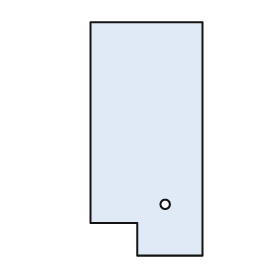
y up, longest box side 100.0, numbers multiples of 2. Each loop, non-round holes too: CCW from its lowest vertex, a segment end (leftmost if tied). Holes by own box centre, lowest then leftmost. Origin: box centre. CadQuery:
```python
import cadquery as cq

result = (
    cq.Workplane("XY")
    .moveTo(-4.0, -50.0)
    .lineTo(24.0, -50.0)
    .lineTo(24.0, 50.0)
    .lineTo(-24.0, 50.0)
    .lineTo(-24.0, -36.0)
    .lineTo(-4.0, -36.0)
    .close()
    .moveTo(8.0, -28.0)
    .circle(2.0)
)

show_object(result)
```